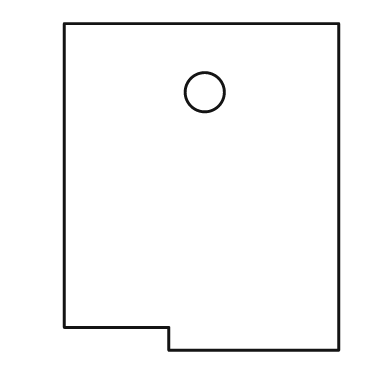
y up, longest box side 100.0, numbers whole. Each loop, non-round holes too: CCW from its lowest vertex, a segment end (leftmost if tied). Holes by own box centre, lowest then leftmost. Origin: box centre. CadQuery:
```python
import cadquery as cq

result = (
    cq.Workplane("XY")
    .moveTo(-10.0, -50.0)
    .lineTo(42.0, -50.0)
    .lineTo(42.0, 50.0)
    .lineTo(-42.0, 50.0)
    .lineTo(-42.0, -43.0)
    .lineTo(-10.0, -43.0)
    .close()
    .moveTo(1.0, 29.0)
    .circle(6.0)
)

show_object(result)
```